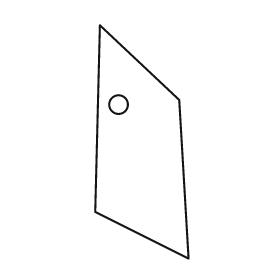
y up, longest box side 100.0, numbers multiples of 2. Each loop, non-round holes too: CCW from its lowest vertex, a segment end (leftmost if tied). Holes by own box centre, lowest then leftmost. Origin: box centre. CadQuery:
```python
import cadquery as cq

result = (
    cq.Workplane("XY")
    .moveTo(20.0, -50.0)
    .lineTo(16.0, 18.0)
    .lineTo(-18.0, 50.0)
    .lineTo(-20.0, -30.0)
    .close()
    .moveTo(-10.0, 16.0)
    .circle(4.0)
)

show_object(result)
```